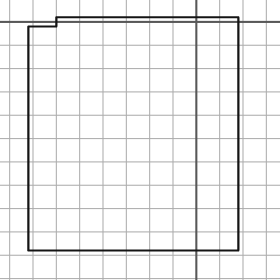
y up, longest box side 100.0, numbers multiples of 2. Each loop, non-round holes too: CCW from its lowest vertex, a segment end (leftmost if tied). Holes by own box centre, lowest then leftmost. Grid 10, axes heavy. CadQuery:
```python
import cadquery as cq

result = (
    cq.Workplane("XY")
    .moveTo(-72.0, -98.0)
    .lineTo(18.0, -98.0)
    .lineTo(18.0, 2.0)
    .lineTo(-60.0, 2.0)
    .lineTo(-60.0, -2.0)
    .lineTo(-72.0, -2.0)
    .close()
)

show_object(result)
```